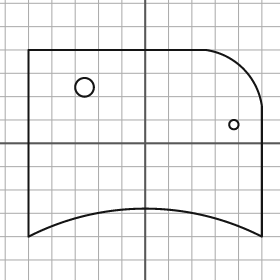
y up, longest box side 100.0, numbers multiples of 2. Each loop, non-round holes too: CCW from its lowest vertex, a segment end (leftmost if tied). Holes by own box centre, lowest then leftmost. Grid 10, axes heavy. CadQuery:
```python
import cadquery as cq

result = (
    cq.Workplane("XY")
    .moveTo(-50.0, -40.0)
    .threePointArc((0.0, -28.0), (50.0, -40.0))
    .lineTo(50.0, 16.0)
    .threePointArc((42.0, 32.0), (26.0, 40.0))
    .lineTo(-50.0, 40.0)
    .close()
    .moveTo(38.0, 8.0)
    .circle(2.0)
    .moveTo(-26.0, 24.0)
    .circle(4.0)
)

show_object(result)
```